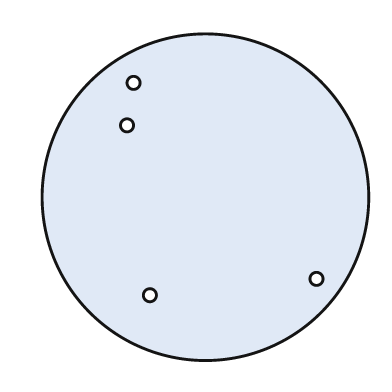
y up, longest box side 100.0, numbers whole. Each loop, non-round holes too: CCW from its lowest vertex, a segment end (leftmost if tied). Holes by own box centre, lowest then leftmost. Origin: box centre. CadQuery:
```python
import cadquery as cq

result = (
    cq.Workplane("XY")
    .moveTo(0.0, 0.0)
    .circle(50.0)
    .moveTo(-17.0, -30.0)
    .circle(2.0)
    .moveTo(34.0, -25.0)
    .circle(2.0)
    .moveTo(-24.0, 22.0)
    .circle(2.0)
    .moveTo(-22.0, 35.0)
    .circle(2.0)
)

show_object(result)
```